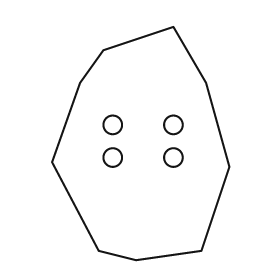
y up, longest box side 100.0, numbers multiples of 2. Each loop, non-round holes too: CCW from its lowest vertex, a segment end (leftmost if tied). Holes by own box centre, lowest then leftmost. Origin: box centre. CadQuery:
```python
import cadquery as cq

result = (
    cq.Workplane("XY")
    .moveTo(-2.0, -50.0)
    .lineTo(26.0, -46.0)
    .lineTo(38.0, -10.0)
    .lineTo(28.0, 26.0)
    .lineTo(14.0, 50.0)
    .lineTo(-16.0, 40.0)
    .lineTo(-26.0, 26.0)
    .lineTo(-38.0, -8.0)
    .lineTo(-18.0, -46.0)
    .close()
    .moveTo(-12.0, -6.0)
    .circle(4.0)
    .moveTo(14.0, -6.0)
    .circle(4.0)
    .moveTo(-12.0, 8.0)
    .circle(4.0)
    .moveTo(14.0, 8.0)
    .circle(4.0)
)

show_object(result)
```